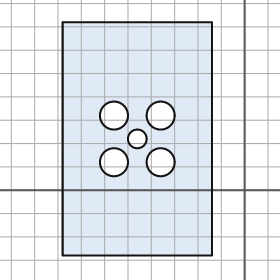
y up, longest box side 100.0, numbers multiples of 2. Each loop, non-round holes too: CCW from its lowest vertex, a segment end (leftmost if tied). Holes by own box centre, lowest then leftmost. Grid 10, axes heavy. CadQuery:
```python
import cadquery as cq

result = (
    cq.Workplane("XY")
    .moveTo(-78.0, -28.0)
    .lineTo(-14.0, -28.0)
    .lineTo(-14.0, 72.0)
    .lineTo(-78.0, 72.0)
    .close()
    .moveTo(-56.0, 12.0)
    .circle(6.0)
    .moveTo(-36.0, 12.0)
    .circle(6.0)
    .moveTo(-46.0, 22.0)
    .circle(4.0)
    .moveTo(-56.0, 32.0)
    .circle(6.0)
    .moveTo(-36.0, 32.0)
    .circle(6.0)
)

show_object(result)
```